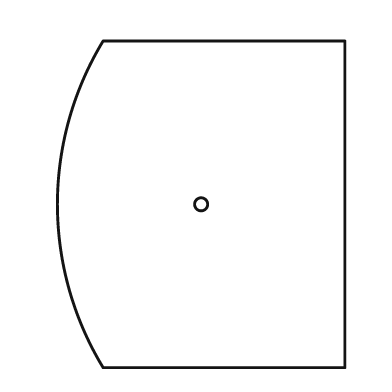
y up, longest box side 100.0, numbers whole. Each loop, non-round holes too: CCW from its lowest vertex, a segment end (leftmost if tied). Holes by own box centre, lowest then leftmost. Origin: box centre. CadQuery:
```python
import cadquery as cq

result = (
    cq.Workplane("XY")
    .moveTo(-30.0, -50.0)
    .lineTo(44.0, -50.0)
    .lineTo(44.0, 50.0)
    .lineTo(-30.0, 50.0)
    .threePointArc((-44.0, 0.0), (-30.0, -50.0))
    .close()
    .moveTo(0.0, 0.0)
    .circle(2.0)
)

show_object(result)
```